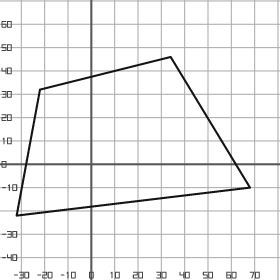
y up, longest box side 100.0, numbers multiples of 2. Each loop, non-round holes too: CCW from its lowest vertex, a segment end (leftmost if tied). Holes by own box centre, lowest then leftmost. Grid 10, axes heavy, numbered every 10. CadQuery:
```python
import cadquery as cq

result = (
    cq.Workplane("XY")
    .moveTo(-32.0, -22.0)
    .lineTo(68.0, -10.0)
    .lineTo(34.0, 46.0)
    .lineTo(-22.0, 32.0)
    .close()
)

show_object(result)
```